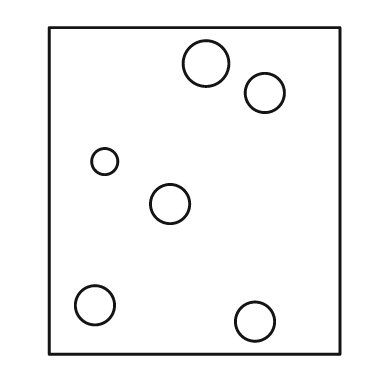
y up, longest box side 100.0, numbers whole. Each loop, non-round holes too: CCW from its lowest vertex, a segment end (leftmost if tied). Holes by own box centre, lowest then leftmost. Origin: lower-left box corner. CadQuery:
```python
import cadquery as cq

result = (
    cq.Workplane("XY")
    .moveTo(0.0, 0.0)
    .lineTo(89.0, 0.0)
    .lineTo(89.0, 100.0)
    .lineTo(0.0, 100.0)
    .close()
    .moveTo(63.0, 10.0)
    .circle(6.0)
    .moveTo(14.0, 15.0)
    .circle(6.0)
    .moveTo(37.0, 46.0)
    .circle(6.0)
    .moveTo(17.0, 59.0)
    .circle(4.0)
    .moveTo(66.0, 80.0)
    .circle(6.0)
    .moveTo(48.0, 89.0)
    .circle(7.0)
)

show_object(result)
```